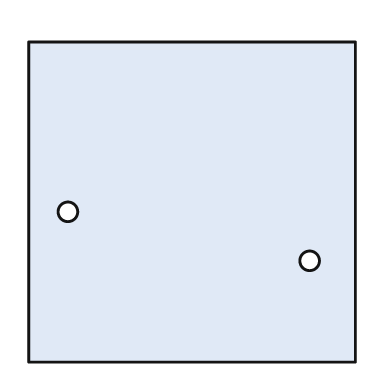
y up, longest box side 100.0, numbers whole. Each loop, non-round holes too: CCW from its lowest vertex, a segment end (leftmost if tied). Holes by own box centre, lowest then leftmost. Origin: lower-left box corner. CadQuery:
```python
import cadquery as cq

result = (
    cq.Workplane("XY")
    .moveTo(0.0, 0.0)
    .lineTo(100.0, 0.0)
    .lineTo(100.0, 98.0)
    .lineTo(0.0, 98.0)
    .close()
    .moveTo(86.0, 31.0)
    .circle(3.0)
    .moveTo(12.0, 46.0)
    .circle(3.0)
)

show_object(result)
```